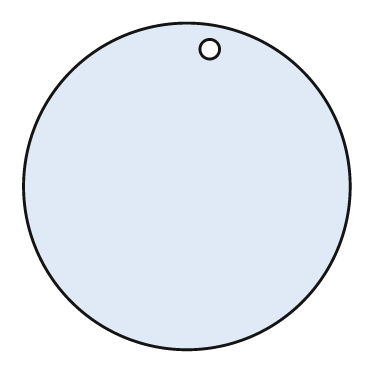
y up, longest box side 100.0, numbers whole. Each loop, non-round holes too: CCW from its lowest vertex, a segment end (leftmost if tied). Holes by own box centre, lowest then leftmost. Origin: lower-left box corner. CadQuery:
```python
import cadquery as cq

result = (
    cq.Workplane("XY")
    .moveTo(50.0, 50.0)
    .circle(50.0)
    .moveTo(57.0, 92.0)
    .circle(3.0)
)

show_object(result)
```